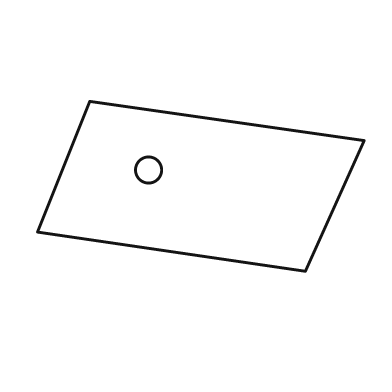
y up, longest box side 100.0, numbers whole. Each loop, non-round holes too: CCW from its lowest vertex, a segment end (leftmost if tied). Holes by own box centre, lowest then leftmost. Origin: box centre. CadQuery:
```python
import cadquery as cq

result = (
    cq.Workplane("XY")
    .moveTo(32.0, -26.0)
    .lineTo(50.0, 14.0)
    .lineTo(-34.0, 26.0)
    .lineTo(-50.0, -14.0)
    .close()
    .moveTo(-16.0, 5.0)
    .circle(4.0)
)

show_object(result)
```